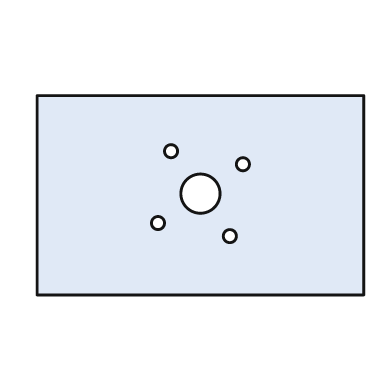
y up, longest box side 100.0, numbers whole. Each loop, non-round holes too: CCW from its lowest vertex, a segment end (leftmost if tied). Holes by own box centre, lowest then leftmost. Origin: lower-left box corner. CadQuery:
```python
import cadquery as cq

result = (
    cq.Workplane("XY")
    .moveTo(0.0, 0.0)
    .lineTo(100.0, 0.0)
    .lineTo(100.0, 61.0)
    .lineTo(0.0, 61.0)
    .close()
    .moveTo(59.0, 18.0)
    .circle(2.0)
    .moveTo(37.0, 22.0)
    .circle(2.0)
    .moveTo(50.0, 31.0)
    .circle(6.0)
    .moveTo(63.0, 40.0)
    .circle(2.0)
    .moveTo(41.0, 44.0)
    .circle(2.0)
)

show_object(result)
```